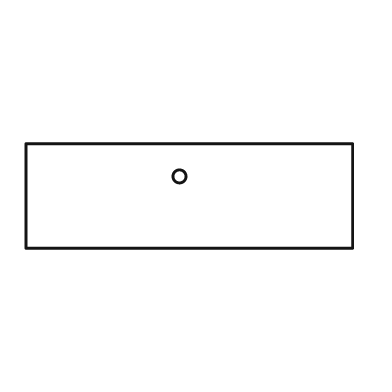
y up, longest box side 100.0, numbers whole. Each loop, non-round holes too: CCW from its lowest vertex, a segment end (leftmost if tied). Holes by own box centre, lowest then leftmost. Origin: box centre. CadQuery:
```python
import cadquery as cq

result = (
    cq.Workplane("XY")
    .moveTo(-50.0, -16.0)
    .lineTo(50.0, -16.0)
    .lineTo(50.0, 16.0)
    .lineTo(-50.0, 16.0)
    .close()
    .moveTo(-3.0, 6.0)
    .circle(2.0)
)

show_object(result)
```